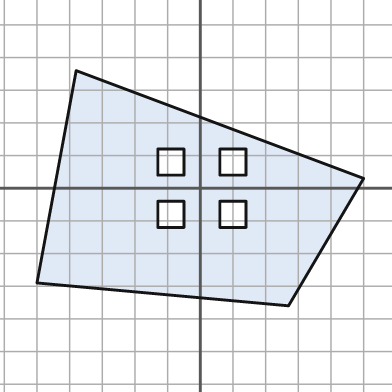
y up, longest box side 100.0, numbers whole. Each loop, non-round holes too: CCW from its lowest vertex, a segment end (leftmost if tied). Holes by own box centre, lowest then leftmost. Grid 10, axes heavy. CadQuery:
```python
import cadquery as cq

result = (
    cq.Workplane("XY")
    .moveTo(27.0, -36.0)
    .lineTo(50.0, 3.0)
    .lineTo(-38.0, 36.0)
    .lineTo(-50.0, -29.0)
    .close()
    .moveTo(-13.0, -12.0)
    .lineTo(-5.0, -12.0)
    .lineTo(-5.0, -4.0)
    .lineTo(-13.0, -4.0)
    .close()
    .moveTo(6.0, -12.0)
    .lineTo(14.0, -12.0)
    .lineTo(14.0, -4.0)
    .lineTo(6.0, -4.0)
    .close()
    .moveTo(-13.0, 4.0)
    .lineTo(-5.0, 4.0)
    .lineTo(-5.0, 12.0)
    .lineTo(-13.0, 12.0)
    .close()
    .moveTo(6.0, 4.0)
    .lineTo(14.0, 4.0)
    .lineTo(14.0, 12.0)
    .lineTo(6.0, 12.0)
    .close()
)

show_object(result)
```